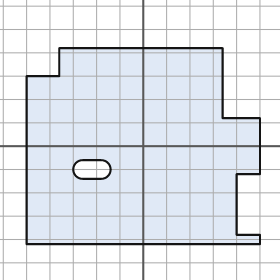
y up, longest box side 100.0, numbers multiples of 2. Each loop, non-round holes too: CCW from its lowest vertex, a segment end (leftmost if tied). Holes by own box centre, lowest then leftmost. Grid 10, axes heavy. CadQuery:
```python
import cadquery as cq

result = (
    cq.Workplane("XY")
    .moveTo(-50.0, -42.0)
    .lineTo(50.0, -42.0)
    .lineTo(50.0, -38.0)
    .lineTo(40.0, -38.0)
    .lineTo(40.0, -12.0)
    .lineTo(50.0, -12.0)
    .lineTo(50.0, 12.0)
    .lineTo(34.0, 12.0)
    .lineTo(34.0, 42.0)
    .lineTo(-36.0, 42.0)
    .lineTo(-36.0, 30.0)
    .lineTo(-50.0, 30.0)
    .close()
    .moveTo(-26.0, -14.0)
    .lineTo(-18.0, -14.0)
    .threePointArc((-14.0, -10.0), (-18.0, -6.0))
    .lineTo(-26.0, -6.0)
    .threePointArc((-30.0, -10.0), (-26.0, -14.0))
    .close()
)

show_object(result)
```